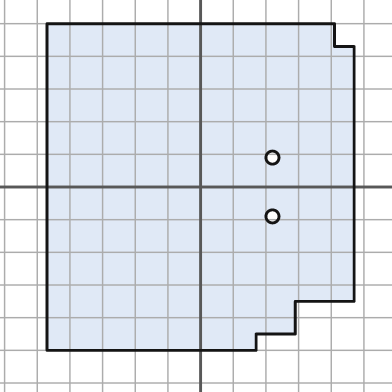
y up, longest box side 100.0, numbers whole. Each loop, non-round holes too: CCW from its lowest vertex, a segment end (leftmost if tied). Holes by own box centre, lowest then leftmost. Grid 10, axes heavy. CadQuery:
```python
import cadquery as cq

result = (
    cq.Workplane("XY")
    .moveTo(-47.0, -50.0)
    .lineTo(17.0, -50.0)
    .lineTo(17.0, -45.0)
    .lineTo(29.0, -45.0)
    .lineTo(29.0, -35.0)
    .lineTo(47.0, -35.0)
    .lineTo(47.0, 43.0)
    .lineTo(41.0, 43.0)
    .lineTo(41.0, 50.0)
    .lineTo(-47.0, 50.0)
    .close()
    .moveTo(22.0, -9.0)
    .circle(2.0)
    .moveTo(22.0, 9.0)
    .circle(2.0)
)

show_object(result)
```